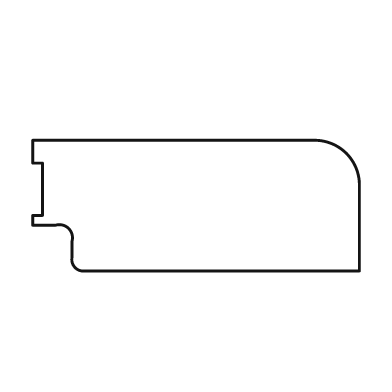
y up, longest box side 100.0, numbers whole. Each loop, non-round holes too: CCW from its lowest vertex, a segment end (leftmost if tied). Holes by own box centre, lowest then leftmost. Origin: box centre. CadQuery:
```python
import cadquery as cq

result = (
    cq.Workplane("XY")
    .moveTo(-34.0, -20.0)
    .lineTo(50.0, -20.0)
    .lineTo(50.0, 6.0)
    .threePointArc((46.0, 16.0), (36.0, 20.0))
    .lineTo(-50.0, 20.0)
    .lineTo(-50.0, 13.0)
    .lineTo(-47.0, 13.0)
    .lineTo(-47.0, -3.0)
    .lineTo(-50.0, -3.0)
    .lineTo(-50.0, -6.0)
    .lineTo(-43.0, -6.0)
    .threePointArc((-39.0, -7.0), (-38.0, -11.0))
    .lineTo(-38.0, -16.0)
    .threePointArc((-37.0, -19.0), (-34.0, -20.0))
    .close()
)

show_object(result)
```